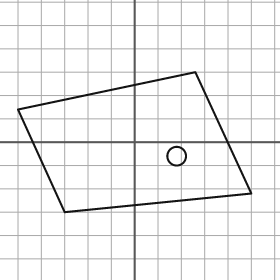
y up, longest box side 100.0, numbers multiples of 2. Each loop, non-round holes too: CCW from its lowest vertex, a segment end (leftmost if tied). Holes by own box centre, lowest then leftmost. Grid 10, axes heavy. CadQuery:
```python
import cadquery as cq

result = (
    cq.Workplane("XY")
    .moveTo(-30.0, -30.0)
    .lineTo(50.0, -22.0)
    .lineTo(26.0, 30.0)
    .lineTo(-50.0, 14.0)
    .close()
    .moveTo(18.0, -6.0)
    .circle(4.0)
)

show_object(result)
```